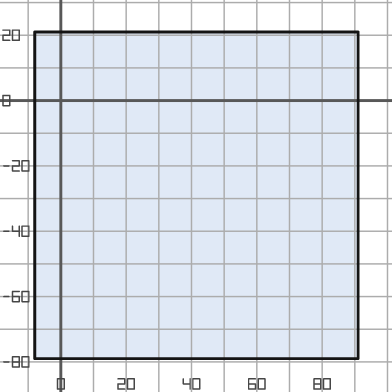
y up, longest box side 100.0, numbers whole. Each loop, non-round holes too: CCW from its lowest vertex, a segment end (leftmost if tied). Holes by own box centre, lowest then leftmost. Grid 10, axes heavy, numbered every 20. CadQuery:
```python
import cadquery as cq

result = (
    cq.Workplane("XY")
    .moveTo(-8.0, -79.0)
    .lineTo(91.0, -79.0)
    .lineTo(91.0, 21.0)
    .lineTo(-8.0, 21.0)
    .close()
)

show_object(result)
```